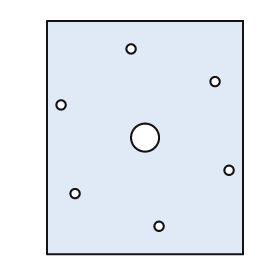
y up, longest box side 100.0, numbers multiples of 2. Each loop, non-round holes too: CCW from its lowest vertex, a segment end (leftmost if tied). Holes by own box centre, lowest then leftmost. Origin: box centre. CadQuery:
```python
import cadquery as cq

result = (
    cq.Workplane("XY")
    .moveTo(-42.0, -50.0)
    .lineTo(42.0, -50.0)
    .lineTo(42.0, 50.0)
    .lineTo(-42.0, 50.0)
    .close()
    .moveTo(6.0, -38.0)
    .circle(2.0)
    .moveTo(-30.0, -24.0)
    .circle(2.0)
    .moveTo(36.0, -14.0)
    .circle(2.0)
    .moveTo(0.0, 0.0)
    .circle(6.0)
    .moveTo(-36.0, 14.0)
    .circle(2.0)
    .moveTo(30.0, 24.0)
    .circle(2.0)
    .moveTo(-6.0, 38.0)
    .circle(2.0)
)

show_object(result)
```